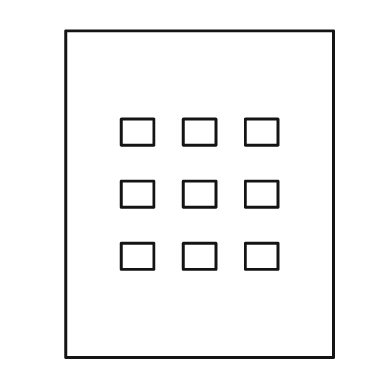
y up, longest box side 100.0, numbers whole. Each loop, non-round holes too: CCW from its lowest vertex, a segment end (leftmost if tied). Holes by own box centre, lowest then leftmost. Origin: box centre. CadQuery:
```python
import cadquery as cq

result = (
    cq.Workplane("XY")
    .moveTo(-41.0, -50.0)
    .lineTo(41.0, -50.0)
    .lineTo(41.0, 50.0)
    .lineTo(-41.0, 50.0)
    .close()
    .moveTo(-24.0, -23.0)
    .lineTo(-14.0, -23.0)
    .lineTo(-14.0, -15.0)
    .lineTo(-24.0, -15.0)
    .close()
    .moveTo(-5.0, -23.0)
    .lineTo(5.0, -23.0)
    .lineTo(5.0, -15.0)
    .lineTo(-5.0, -15.0)
    .close()
    .moveTo(14.0, -23.0)
    .lineTo(24.0, -23.0)
    .lineTo(24.0, -15.0)
    .lineTo(14.0, -15.0)
    .close()
    .moveTo(-24.0, -4.0)
    .lineTo(-14.0, -4.0)
    .lineTo(-14.0, 4.0)
    .lineTo(-24.0, 4.0)
    .close()
    .moveTo(-5.0, -4.0)
    .lineTo(5.0, -4.0)
    .lineTo(5.0, 4.0)
    .lineTo(-5.0, 4.0)
    .close()
    .moveTo(14.0, -4.0)
    .lineTo(24.0, -4.0)
    .lineTo(24.0, 4.0)
    .lineTo(14.0, 4.0)
    .close()
    .moveTo(-24.0, 15.0)
    .lineTo(-14.0, 15.0)
    .lineTo(-14.0, 23.0)
    .lineTo(-24.0, 23.0)
    .close()
    .moveTo(-5.0, 15.0)
    .lineTo(5.0, 15.0)
    .lineTo(5.0, 23.0)
    .lineTo(-5.0, 23.0)
    .close()
    .moveTo(14.0, 15.0)
    .lineTo(24.0, 15.0)
    .lineTo(24.0, 23.0)
    .lineTo(14.0, 23.0)
    .close()
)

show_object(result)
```